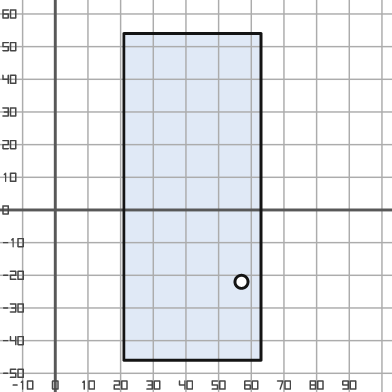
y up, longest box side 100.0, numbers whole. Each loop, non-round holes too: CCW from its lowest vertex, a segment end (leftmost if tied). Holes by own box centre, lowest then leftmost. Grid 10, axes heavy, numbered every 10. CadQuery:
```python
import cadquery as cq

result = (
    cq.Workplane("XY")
    .moveTo(21.0, -46.0)
    .lineTo(63.0, -46.0)
    .lineTo(63.0, 54.0)
    .lineTo(21.0, 54.0)
    .close()
    .moveTo(57.0, -22.0)
    .circle(2.0)
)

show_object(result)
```